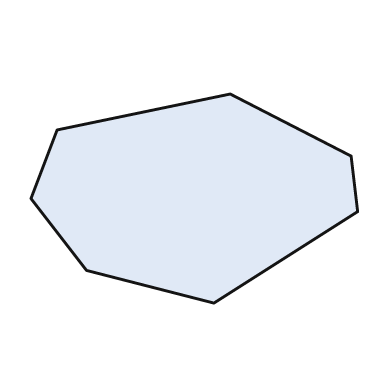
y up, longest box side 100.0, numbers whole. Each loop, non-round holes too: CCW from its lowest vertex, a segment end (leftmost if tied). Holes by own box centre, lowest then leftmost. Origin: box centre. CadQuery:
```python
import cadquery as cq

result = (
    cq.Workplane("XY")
    .moveTo(6.0, -32.0)
    .lineTo(50.0, -4.0)
    .lineTo(48.0, 13.0)
    .lineTo(11.0, 32.0)
    .lineTo(-42.0, 21.0)
    .lineTo(-50.0, 0.0)
    .lineTo(-33.0, -22.0)
    .close()
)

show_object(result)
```